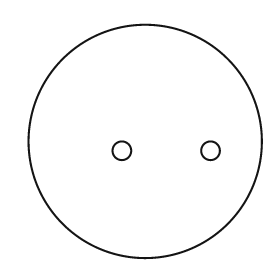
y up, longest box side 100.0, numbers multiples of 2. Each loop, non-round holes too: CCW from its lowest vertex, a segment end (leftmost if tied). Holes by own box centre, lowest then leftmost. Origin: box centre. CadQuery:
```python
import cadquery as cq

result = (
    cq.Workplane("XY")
    .moveTo(0.0, 0.0)
    .circle(50.0)
    .moveTo(-10.0, -4.0)
    .circle(4.0)
    .moveTo(28.0, -4.0)
    .circle(4.0)
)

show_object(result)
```